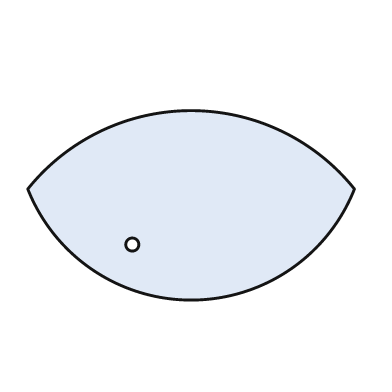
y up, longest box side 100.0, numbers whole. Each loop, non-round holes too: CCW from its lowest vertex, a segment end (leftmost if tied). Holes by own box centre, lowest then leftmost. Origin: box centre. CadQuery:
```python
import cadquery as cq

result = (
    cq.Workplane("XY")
    .moveTo(-50.0, 5.0)
    .threePointArc((0.0, -29.0), (50.0, 5.0))
    .threePointArc((0.0, 29.0), (-50.0, 5.0))
    .close()
    .moveTo(-18.0, -12.0)
    .circle(2.0)
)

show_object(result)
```